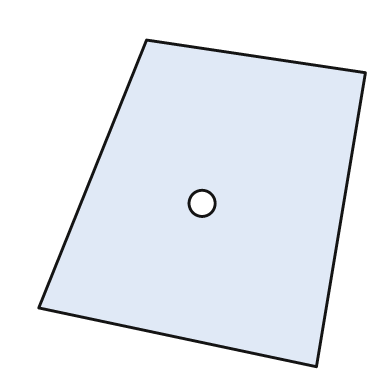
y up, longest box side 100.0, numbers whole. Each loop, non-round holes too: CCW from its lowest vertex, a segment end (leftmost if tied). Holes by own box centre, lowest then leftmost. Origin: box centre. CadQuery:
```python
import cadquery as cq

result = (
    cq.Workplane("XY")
    .moveTo(35.0, -50.0)
    .lineTo(50.0, 40.0)
    .lineTo(-17.0, 50.0)
    .lineTo(-50.0, -32.0)
    .close()
    .moveTo(0.0, 0.0)
    .circle(4.0)
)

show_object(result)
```